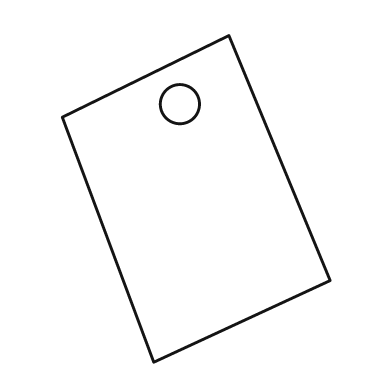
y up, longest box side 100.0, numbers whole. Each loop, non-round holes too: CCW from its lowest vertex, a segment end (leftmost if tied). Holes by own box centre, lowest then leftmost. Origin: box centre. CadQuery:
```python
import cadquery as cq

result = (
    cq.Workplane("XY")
    .moveTo(-13.0, -50.0)
    .lineTo(41.0, -25.0)
    .lineTo(10.0, 50.0)
    .lineTo(-41.0, 25.0)
    .close()
    .moveTo(-5.0, 29.0)
    .circle(6.0)
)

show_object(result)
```